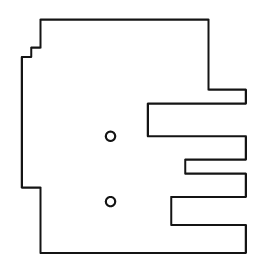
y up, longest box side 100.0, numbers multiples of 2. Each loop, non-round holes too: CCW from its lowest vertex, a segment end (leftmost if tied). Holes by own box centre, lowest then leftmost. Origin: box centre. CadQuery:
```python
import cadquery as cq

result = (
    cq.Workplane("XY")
    .moveTo(-40.0, -50.0)
    .lineTo(48.0, -50.0)
    .lineTo(48.0, -38.0)
    .lineTo(16.0, -38.0)
    .lineTo(16.0, -26.0)
    .lineTo(48.0, -26.0)
    .lineTo(48.0, -16.0)
    .lineTo(22.0, -16.0)
    .lineTo(22.0, -10.0)
    .lineTo(48.0, -10.0)
    .lineTo(48.0, 0.0)
    .lineTo(6.0, 0.0)
    .lineTo(6.0, 14.0)
    .lineTo(48.0, 14.0)
    .lineTo(48.0, 20.0)
    .lineTo(32.0, 20.0)
    .lineTo(32.0, 50.0)
    .lineTo(-40.0, 50.0)
    .lineTo(-40.0, 38.0)
    .lineTo(-44.0, 38.0)
    .lineTo(-44.0, 34.0)
    .lineTo(-48.0, 34.0)
    .lineTo(-48.0, -22.0)
    .lineTo(-40.0, -22.0)
    .close()
    .moveTo(-10.0, -28.0)
    .circle(2.0)
    .moveTo(-10.0, 0.0)
    .circle(2.0)
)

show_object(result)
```